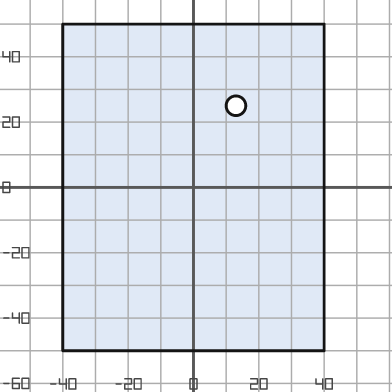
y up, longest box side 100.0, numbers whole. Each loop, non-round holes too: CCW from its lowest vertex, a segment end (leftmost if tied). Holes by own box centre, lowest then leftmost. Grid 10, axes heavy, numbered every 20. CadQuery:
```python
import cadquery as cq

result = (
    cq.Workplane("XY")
    .moveTo(-40.0, -50.0)
    .lineTo(40.0, -50.0)
    .lineTo(40.0, 50.0)
    .lineTo(-40.0, 50.0)
    .close()
    .moveTo(13.0, 25.0)
    .circle(3.0)
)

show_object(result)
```